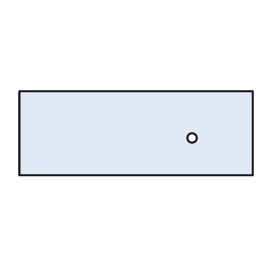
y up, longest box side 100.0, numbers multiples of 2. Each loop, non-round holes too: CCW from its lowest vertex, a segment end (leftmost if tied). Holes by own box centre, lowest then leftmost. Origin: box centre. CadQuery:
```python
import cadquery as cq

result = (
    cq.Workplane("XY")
    .moveTo(-50.0, -18.0)
    .lineTo(50.0, -18.0)
    .lineTo(50.0, 18.0)
    .lineTo(-50.0, 18.0)
    .close()
    .moveTo(24.0, -2.0)
    .circle(2.0)
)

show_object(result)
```